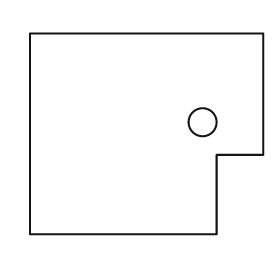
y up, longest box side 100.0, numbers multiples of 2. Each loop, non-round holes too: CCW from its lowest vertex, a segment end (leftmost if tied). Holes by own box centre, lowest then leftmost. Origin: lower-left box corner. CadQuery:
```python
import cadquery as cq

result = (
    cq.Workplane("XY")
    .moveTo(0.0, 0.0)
    .lineTo(80.0, 0.0)
    .lineTo(80.0, 34.0)
    .lineTo(100.0, 34.0)
    .lineTo(100.0, 86.0)
    .lineTo(0.0, 86.0)
    .close()
    .moveTo(74.0, 48.0)
    .circle(6.0)
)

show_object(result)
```